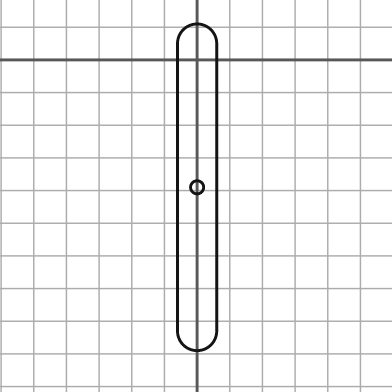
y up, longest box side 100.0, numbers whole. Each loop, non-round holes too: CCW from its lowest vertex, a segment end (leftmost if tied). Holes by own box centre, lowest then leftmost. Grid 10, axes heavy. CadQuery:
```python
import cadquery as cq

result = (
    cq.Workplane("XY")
    .moveTo(-6.0, -83.0)
    .threePointArc((0.0, -89.0), (6.0, -83.0))
    .lineTo(6.0, 5.0)
    .threePointArc((0.0, 11.0), (-6.0, 5.0))
    .close()
    .moveTo(0.0, -39.0)
    .circle(2.0)
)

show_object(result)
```